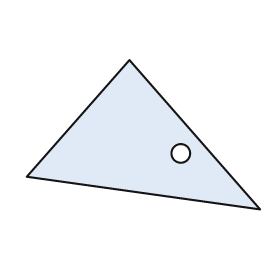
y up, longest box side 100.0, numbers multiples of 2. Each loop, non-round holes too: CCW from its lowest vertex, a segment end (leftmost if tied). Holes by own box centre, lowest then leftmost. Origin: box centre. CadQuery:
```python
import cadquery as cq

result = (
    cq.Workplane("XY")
    .moveTo(50.0, -32.0)
    .lineTo(-6.0, 32.0)
    .lineTo(-50.0, -18.0)
    .close()
    .moveTo(16.0, -8.0)
    .circle(4.0)
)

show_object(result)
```